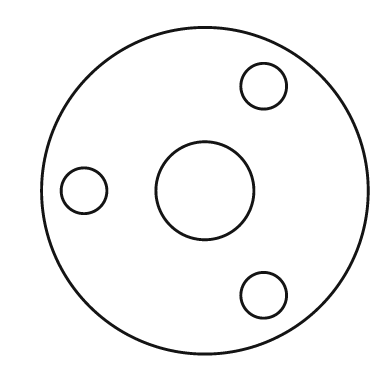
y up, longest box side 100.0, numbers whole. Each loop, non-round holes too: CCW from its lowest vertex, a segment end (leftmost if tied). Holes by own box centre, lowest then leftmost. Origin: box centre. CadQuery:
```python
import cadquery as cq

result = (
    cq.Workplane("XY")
    .moveTo(0.0, 0.0)
    .circle(50.0)
    .moveTo(18.0, -32.0)
    .circle(7.0)
    .moveTo(-37.0, 0.0)
    .circle(7.0)
    .moveTo(0.0, 0.0)
    .circle(15.0)
    .moveTo(18.0, 32.0)
    .circle(7.0)
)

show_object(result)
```